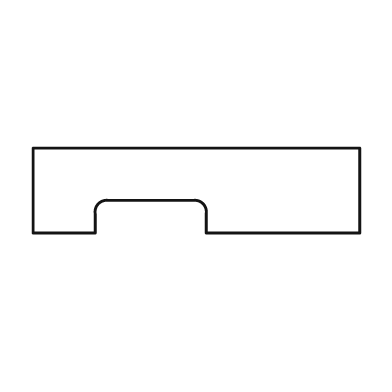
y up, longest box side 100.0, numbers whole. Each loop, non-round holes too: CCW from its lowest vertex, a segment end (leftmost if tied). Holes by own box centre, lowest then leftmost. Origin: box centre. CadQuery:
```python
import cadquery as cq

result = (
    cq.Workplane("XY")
    .moveTo(-50.0, -13.0)
    .lineTo(-31.0, -13.0)
    .lineTo(-31.0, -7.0)
    .threePointArc((-30.0, -4.0), (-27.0, -3.0))
    .lineTo(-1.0, -3.0)
    .threePointArc((2.0, -4.0), (3.0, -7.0))
    .lineTo(3.0, -13.0)
    .lineTo(50.0, -13.0)
    .lineTo(50.0, 13.0)
    .lineTo(-50.0, 13.0)
    .close()
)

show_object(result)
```